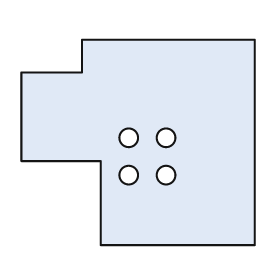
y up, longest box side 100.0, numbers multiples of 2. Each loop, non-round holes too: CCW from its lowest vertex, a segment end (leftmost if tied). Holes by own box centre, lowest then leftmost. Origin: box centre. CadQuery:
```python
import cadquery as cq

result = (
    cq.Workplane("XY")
    .moveTo(-16.0, -44.0)
    .lineTo(50.0, -44.0)
    .lineTo(50.0, 44.0)
    .lineTo(-24.0, 44.0)
    .lineTo(-24.0, 30.0)
    .lineTo(-50.0, 30.0)
    .lineTo(-50.0, -8.0)
    .lineTo(-16.0, -8.0)
    .close()
    .moveTo(-4.0, -14.0)
    .circle(4.0)
    .moveTo(12.0, -14.0)
    .circle(4.0)
    .moveTo(-4.0, 2.0)
    .circle(4.0)
    .moveTo(12.0, 2.0)
    .circle(4.0)
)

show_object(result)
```